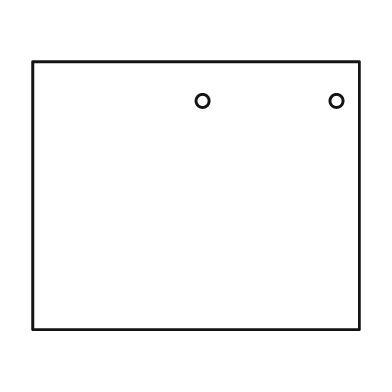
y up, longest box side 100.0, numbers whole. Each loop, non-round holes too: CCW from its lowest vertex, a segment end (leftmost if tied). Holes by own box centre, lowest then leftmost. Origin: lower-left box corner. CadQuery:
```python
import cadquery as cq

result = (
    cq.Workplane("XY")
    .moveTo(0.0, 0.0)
    .lineTo(100.0, 0.0)
    .lineTo(100.0, 82.0)
    .lineTo(0.0, 82.0)
    .close()
    .moveTo(52.0, 70.0)
    .circle(2.0)
    .moveTo(93.0, 70.0)
    .circle(2.0)
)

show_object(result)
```